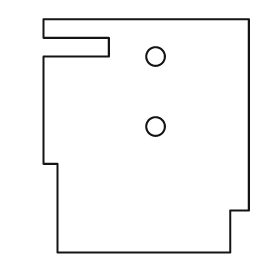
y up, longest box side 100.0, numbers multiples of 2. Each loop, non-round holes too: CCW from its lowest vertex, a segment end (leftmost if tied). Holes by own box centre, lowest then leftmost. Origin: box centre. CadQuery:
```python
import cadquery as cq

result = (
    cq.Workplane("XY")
    .moveTo(-38.0, -50.0)
    .lineTo(36.0, -50.0)
    .lineTo(36.0, -32.0)
    .lineTo(44.0, -32.0)
    .lineTo(44.0, 50.0)
    .lineTo(-44.0, 50.0)
    .lineTo(-44.0, 42.0)
    .lineTo(-16.0, 42.0)
    .lineTo(-16.0, 34.0)
    .lineTo(-44.0, 34.0)
    .lineTo(-44.0, -12.0)
    .lineTo(-38.0, -12.0)
    .close()
    .moveTo(4.0, 4.0)
    .circle(4.0)
    .moveTo(4.0, 34.0)
    .circle(4.0)
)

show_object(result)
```